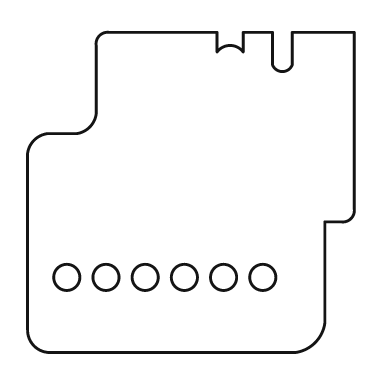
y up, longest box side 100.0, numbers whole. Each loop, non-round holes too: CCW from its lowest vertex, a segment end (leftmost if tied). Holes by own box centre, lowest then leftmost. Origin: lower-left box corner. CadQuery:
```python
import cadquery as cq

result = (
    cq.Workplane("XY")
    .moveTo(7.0, 0.0)
    .lineTo(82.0, 0.0)
    .threePointArc((88.0, 3.0), (91.0, 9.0))
    .lineTo(91.0, 40.0)
    .lineTo(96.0, 40.0)
    .threePointArc((99.0, 41.0), (100.0, 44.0))
    .lineTo(100.0, 98.0)
    .lineTo(81.0, 98.0)
    .lineTo(81.0, 88.0)
    .threePointArc((78.0, 86.0), (75.0, 88.0))
    .lineTo(75.0, 98.0)
    .lineTo(66.0, 98.0)
    .lineTo(66.0, 92.0)
    .threePointArc((62.0, 94.0), (58.0, 92.0))
    .lineTo(58.0, 98.0)
    .lineTo(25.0, 98.0)
    .threePointArc((22.0, 97.0), (21.0, 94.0))
    .lineTo(21.0, 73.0)
    .threePointArc((19.0, 69.0), (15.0, 67.0))
    .lineTo(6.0, 67.0)
    .threePointArc((2.0, 65.0), (0.0, 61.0))
    .lineTo(0.0, 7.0)
    .threePointArc((2.0, 2.0), (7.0, 0.0))
    .close()
    .moveTo(12.0, 23.0)
    .circle(4.0)
    .moveTo(24.0, 23.0)
    .circle(4.0)
    .moveTo(36.0, 23.0)
    .circle(4.0)
    .moveTo(48.0, 23.0)
    .circle(4.0)
    .moveTo(60.0, 23.0)
    .circle(4.0)
    .moveTo(72.0, 23.0)
    .circle(4.0)
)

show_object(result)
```